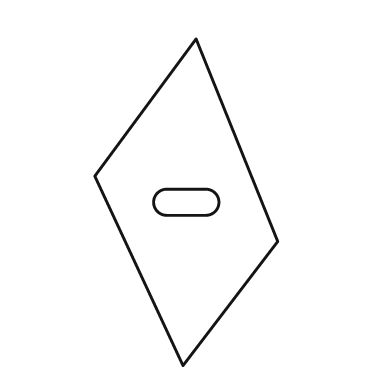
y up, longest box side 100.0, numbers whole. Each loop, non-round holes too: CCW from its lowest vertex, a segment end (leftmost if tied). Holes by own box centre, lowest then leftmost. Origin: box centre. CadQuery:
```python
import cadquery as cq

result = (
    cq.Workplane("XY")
    .moveTo(-1.0, -50.0)
    .lineTo(28.0, -12.0)
    .lineTo(3.0, 50.0)
    .lineTo(-28.0, 8.0)
    .close()
    .moveTo(-6.0, -4.0)
    .lineTo(6.0, -4.0)
    .threePointArc((10.0, 0.0), (6.0, 4.0))
    .lineTo(-6.0, 4.0)
    .threePointArc((-10.0, 0.0), (-6.0, -4.0))
    .close()
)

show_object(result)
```